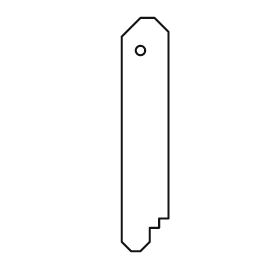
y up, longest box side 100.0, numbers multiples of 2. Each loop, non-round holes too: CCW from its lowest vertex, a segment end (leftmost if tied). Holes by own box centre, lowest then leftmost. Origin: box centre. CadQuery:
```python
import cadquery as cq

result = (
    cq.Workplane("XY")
    .moveTo(-6.0, -50.0)
    .lineTo(-2.0, -50.0)
    .lineTo(2.0, -46.0)
    .lineTo(2.0, -40.0)
    .lineTo(6.0, -40.0)
    .lineTo(6.0, -36.0)
    .lineTo(10.0, -36.0)
    .lineTo(10.0, 44.0)
    .lineTo(4.0, 50.0)
    .lineTo(-2.0, 50.0)
    .lineTo(-10.0, 42.0)
    .lineTo(-10.0, -46.0)
    .close()
    .moveTo(-2.0, 36.0)
    .circle(2.0)
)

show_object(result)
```